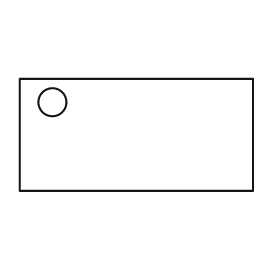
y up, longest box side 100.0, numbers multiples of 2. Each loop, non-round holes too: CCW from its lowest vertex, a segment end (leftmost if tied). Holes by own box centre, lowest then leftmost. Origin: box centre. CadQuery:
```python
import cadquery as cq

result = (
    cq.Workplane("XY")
    .moveTo(-50.0, -24.0)
    .lineTo(50.0, -24.0)
    .lineTo(50.0, 24.0)
    .lineTo(-50.0, 24.0)
    .close()
    .moveTo(-36.0, 14.0)
    .circle(6.0)
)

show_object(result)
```